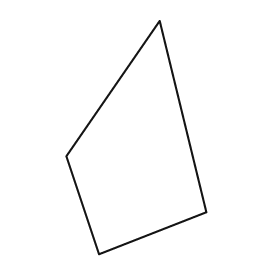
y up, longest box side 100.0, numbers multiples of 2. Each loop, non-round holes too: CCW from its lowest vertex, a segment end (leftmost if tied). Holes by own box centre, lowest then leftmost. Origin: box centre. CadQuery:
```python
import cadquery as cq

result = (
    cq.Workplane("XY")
    .moveTo(-16.0, -50.0)
    .lineTo(30.0, -32.0)
    .lineTo(10.0, 50.0)
    .lineTo(-30.0, -8.0)
    .close()
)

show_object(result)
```